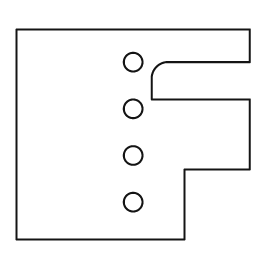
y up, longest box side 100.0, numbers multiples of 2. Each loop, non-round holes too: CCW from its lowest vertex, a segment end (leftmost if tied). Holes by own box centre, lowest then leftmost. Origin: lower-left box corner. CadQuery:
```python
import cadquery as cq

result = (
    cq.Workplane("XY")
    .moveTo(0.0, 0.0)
    .lineTo(72.0, 0.0)
    .lineTo(72.0, 30.0)
    .lineTo(100.0, 30.0)
    .lineTo(100.0, 60.0)
    .lineTo(58.0, 60.0)
    .lineTo(58.0, 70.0)
    .threePointArc((60.0, 74.0), (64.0, 76.0))
    .lineTo(100.0, 76.0)
    .lineTo(100.0, 90.0)
    .lineTo(0.0, 90.0)
    .close()
    .moveTo(50.0, 16.0)
    .circle(4.0)
    .moveTo(50.0, 36.0)
    .circle(4.0)
    .moveTo(50.0, 56.0)
    .circle(4.0)
    .moveTo(50.0, 76.0)
    .circle(4.0)
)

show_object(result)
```